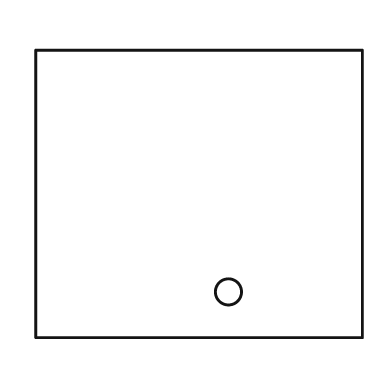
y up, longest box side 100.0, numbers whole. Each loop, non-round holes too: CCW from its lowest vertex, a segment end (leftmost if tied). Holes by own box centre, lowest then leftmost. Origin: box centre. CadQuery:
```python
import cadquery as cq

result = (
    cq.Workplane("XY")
    .moveTo(-50.0, -44.0)
    .lineTo(50.0, -44.0)
    .lineTo(50.0, 44.0)
    .lineTo(-50.0, 44.0)
    .close()
    .moveTo(9.0, -30.0)
    .circle(4.0)
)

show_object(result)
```